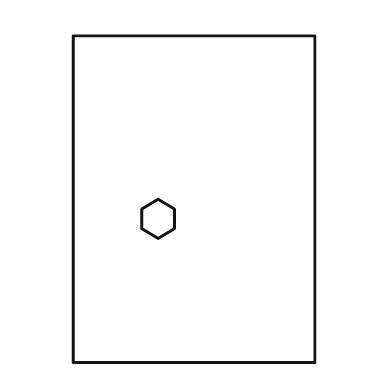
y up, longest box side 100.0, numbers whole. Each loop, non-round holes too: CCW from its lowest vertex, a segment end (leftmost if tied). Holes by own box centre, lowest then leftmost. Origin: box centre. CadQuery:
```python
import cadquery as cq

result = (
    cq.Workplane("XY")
    .moveTo(-37.0, -50.0)
    .lineTo(37.0, -50.0)
    .lineTo(37.0, 50.0)
    .lineTo(-37.0, 50.0)
    .close()
    .moveTo(-11.0, -12.0)
    .lineTo(-6.0, -9.0)
    .lineTo(-6.0, -3.0)
    .lineTo(-11.0, 0.0)
    .lineTo(-16.0, -3.0)
    .lineTo(-16.0, -9.0)
    .close()
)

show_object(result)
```